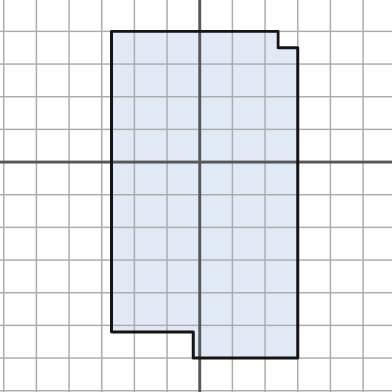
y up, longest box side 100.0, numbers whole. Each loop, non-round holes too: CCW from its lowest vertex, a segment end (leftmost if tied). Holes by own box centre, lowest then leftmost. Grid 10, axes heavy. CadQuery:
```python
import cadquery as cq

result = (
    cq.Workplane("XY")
    .moveTo(-2.0, -60.0)
    .lineTo(30.0, -60.0)
    .lineTo(30.0, 35.0)
    .lineTo(24.0, 35.0)
    .lineTo(24.0, 40.0)
    .lineTo(-27.0, 40.0)
    .lineTo(-27.0, -52.0)
    .lineTo(-2.0, -52.0)
    .close()
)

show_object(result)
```